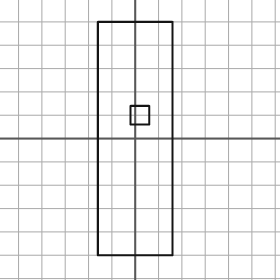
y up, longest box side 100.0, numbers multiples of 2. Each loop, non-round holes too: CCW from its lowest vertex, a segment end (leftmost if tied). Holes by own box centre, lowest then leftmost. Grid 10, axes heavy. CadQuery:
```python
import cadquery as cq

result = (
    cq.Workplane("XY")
    .moveTo(-16.0, -50.0)
    .lineTo(16.0, -50.0)
    .lineTo(16.0, 50.0)
    .lineTo(-16.0, 50.0)
    .close()
    .moveTo(-2.0, 6.0)
    .lineTo(6.0, 6.0)
    .lineTo(6.0, 14.0)
    .lineTo(-2.0, 14.0)
    .close()
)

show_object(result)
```